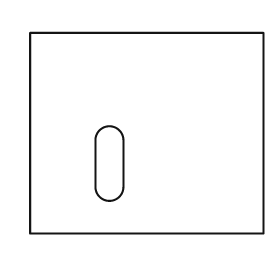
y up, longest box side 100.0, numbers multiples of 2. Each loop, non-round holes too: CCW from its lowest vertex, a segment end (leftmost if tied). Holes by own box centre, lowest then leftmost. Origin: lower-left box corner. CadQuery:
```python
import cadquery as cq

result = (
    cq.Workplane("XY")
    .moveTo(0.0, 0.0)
    .lineTo(100.0, 0.0)
    .lineTo(100.0, 86.0)
    .lineTo(0.0, 86.0)
    .close()
    .moveTo(28.0, 20.0)
    .threePointArc((34.0, 14.0), (40.0, 20.0))
    .lineTo(40.0, 40.0)
    .threePointArc((34.0, 46.0), (28.0, 40.0))
    .close()
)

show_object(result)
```